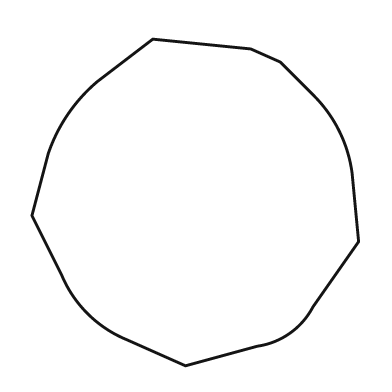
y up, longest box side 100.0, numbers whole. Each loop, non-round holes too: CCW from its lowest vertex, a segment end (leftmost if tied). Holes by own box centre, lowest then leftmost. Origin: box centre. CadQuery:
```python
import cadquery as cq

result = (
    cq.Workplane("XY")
    .moveTo(-3.0, -50.0)
    .lineTo(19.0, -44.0)
    .threePointArc((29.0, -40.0), (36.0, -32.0))
    .lineTo(50.0, -12.0)
    .lineTo(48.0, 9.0)
    .threePointArc((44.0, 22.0), (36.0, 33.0))
    .lineTo(26.0, 43.0)
    .lineTo(17.0, 47.0)
    .lineTo(-13.0, 50.0)
    .lineTo(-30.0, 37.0)
    .threePointArc((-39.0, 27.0), (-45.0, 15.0))
    .lineTo(-50.0, -4.0)
    .lineTo(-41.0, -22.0)
    .threePointArc((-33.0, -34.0), (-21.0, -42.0))
    .close()
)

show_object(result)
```